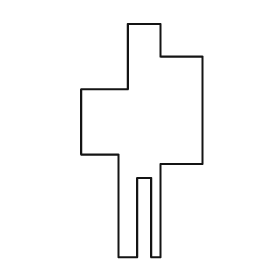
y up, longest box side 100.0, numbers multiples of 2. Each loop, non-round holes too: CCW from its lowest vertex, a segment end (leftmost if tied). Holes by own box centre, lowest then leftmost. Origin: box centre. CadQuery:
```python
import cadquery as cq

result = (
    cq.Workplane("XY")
    .moveTo(-10.0, -50.0)
    .lineTo(-2.0, -50.0)
    .lineTo(-2.0, -16.0)
    .lineTo(4.0, -16.0)
    .lineTo(4.0, -50.0)
    .lineTo(8.0, -50.0)
    .lineTo(8.0, -10.0)
    .lineTo(26.0, -10.0)
    .lineTo(26.0, 36.0)
    .lineTo(8.0, 36.0)
    .lineTo(8.0, 50.0)
    .lineTo(-6.0, 50.0)
    .lineTo(-6.0, 22.0)
    .lineTo(-26.0, 22.0)
    .lineTo(-26.0, -6.0)
    .lineTo(-10.0, -6.0)
    .close()
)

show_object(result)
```